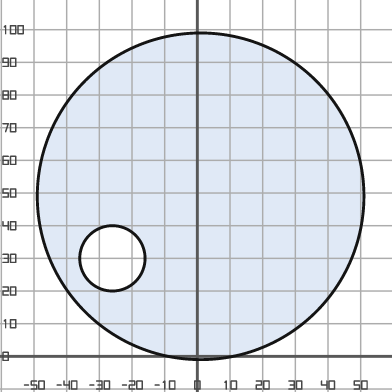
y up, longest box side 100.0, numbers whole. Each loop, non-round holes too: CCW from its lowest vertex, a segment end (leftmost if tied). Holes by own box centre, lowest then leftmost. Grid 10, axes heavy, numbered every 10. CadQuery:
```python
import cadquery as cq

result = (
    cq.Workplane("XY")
    .moveTo(1.0, 49.0)
    .circle(50.0)
    .moveTo(-26.0, 30.0)
    .circle(10.0)
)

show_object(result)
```